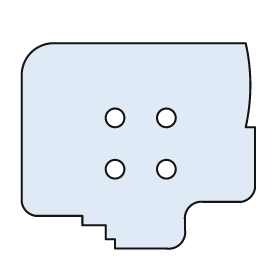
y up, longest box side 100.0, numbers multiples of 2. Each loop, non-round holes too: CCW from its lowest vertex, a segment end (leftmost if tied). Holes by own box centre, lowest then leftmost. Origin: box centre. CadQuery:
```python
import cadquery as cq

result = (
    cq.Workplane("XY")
    .moveTo(-10.0, -44.0)
    .lineTo(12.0, -44.0)
    .threePointArc((18.0, -42.0), (20.0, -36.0))
    .lineTo(20.0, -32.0)
    .threePointArc((22.0, -26.0), (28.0, -24.0))
    .lineTo(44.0, -24.0)
    .threePointArc((48.0, -22.0), (50.0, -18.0))
    .lineTo(50.0, 8.0)
    .lineTo(46.0, 8.0)
    .threePointArc((48.0, 26.0), (46.0, 44.0))
    .lineTo(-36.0, 44.0)
    .threePointArc((-46.0, 40.0), (-50.0, 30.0))
    .lineTo(-50.0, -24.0)
    .threePointArc((-48.0, -28.0), (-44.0, -30.0))
    .lineTo(-24.0, -30.0)
    .lineTo(-24.0, -34.0)
    .lineTo(-14.0, -34.0)
    .lineTo(-14.0, -40.0)
    .lineTo(-10.0, -40.0)
    .close()
    .moveTo(-10.0, -10.0)
    .circle(4.0)
    .moveTo(12.0, -10.0)
    .circle(4.0)
    .moveTo(-10.0, 12.0)
    .circle(4.0)
    .moveTo(12.0, 12.0)
    .circle(4.0)
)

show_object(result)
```